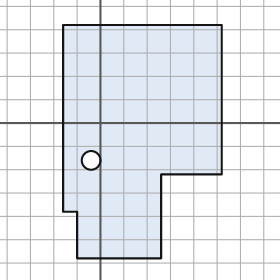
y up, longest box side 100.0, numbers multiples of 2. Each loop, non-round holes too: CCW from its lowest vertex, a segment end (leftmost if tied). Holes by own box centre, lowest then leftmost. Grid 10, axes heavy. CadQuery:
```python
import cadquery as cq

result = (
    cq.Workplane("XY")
    .moveTo(-10.0, -58.0)
    .lineTo(26.0, -58.0)
    .lineTo(26.0, -22.0)
    .lineTo(52.0, -22.0)
    .lineTo(52.0, 42.0)
    .lineTo(-16.0, 42.0)
    .lineTo(-16.0, -38.0)
    .lineTo(-10.0, -38.0)
    .close()
    .moveTo(-4.0, -16.0)
    .circle(4.0)
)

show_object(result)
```